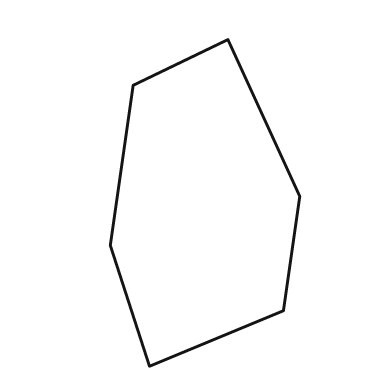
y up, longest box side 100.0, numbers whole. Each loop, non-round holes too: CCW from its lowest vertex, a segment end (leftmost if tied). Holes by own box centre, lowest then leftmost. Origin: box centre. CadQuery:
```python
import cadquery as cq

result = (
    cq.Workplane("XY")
    .moveTo(-17.0, -50.0)
    .lineTo(24.0, -33.0)
    .lineTo(29.0, 2.0)
    .lineTo(7.0, 50.0)
    .lineTo(-22.0, 36.0)
    .lineTo(-29.0, -13.0)
    .close()
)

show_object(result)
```